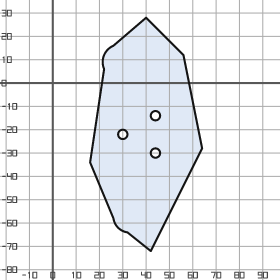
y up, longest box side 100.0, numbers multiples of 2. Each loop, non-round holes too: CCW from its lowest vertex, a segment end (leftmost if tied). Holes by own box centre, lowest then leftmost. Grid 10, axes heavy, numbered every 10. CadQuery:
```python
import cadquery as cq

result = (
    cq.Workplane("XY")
    .moveTo(42.0, -72.0)
    .lineTo(64.0, -28.0)
    .lineTo(56.0, 12.0)
    .lineTo(40.0, 28.0)
    .lineTo(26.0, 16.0)
    .threePointArc((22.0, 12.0), (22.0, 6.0))
    .lineTo(16.0, -34.0)
    .lineTo(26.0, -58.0)
    .threePointArc((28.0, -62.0), (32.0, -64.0))
    .close()
    .moveTo(44.0, -30.0)
    .circle(2.0)
    .moveTo(30.0, -22.0)
    .circle(2.0)
    .moveTo(44.0, -14.0)
    .circle(2.0)
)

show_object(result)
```